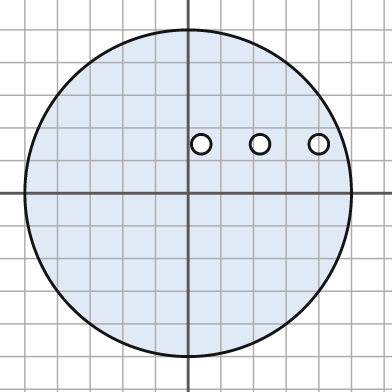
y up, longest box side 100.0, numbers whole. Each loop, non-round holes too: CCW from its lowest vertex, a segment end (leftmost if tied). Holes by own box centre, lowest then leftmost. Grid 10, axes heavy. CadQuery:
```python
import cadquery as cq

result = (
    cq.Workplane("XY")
    .moveTo(0.0, 0.0)
    .circle(50.0)
    .moveTo(4.0, 15.0)
    .circle(3.0)
    .moveTo(22.0, 15.0)
    .circle(3.0)
    .moveTo(40.0, 15.0)
    .circle(3.0)
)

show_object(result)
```